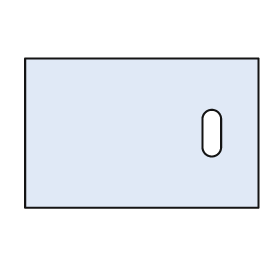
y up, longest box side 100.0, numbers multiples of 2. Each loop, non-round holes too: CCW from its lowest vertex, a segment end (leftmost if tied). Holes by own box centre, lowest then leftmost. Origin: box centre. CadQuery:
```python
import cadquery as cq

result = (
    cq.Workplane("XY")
    .moveTo(-50.0, -32.0)
    .lineTo(50.0, -32.0)
    .lineTo(50.0, 32.0)
    .lineTo(-50.0, 32.0)
    .close()
    .moveTo(26.0, -6.0)
    .threePointArc((30.0, -10.0), (34.0, -6.0))
    .lineTo(34.0, 6.0)
    .threePointArc((30.0, 10.0), (26.0, 6.0))
    .close()
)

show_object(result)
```